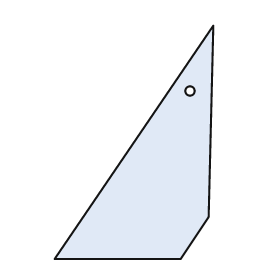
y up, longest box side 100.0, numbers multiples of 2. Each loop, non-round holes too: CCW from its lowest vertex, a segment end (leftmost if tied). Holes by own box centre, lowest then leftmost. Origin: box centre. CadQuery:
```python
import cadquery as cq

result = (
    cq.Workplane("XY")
    .moveTo(-34.0, -50.0)
    .lineTo(20.0, -50.0)
    .lineTo(32.0, -32.0)
    .lineTo(34.0, 50.0)
    .close()
    .moveTo(24.0, 22.0)
    .circle(2.0)
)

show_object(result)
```